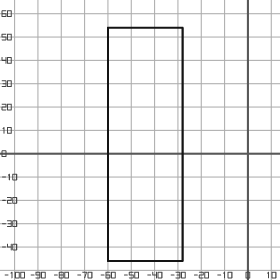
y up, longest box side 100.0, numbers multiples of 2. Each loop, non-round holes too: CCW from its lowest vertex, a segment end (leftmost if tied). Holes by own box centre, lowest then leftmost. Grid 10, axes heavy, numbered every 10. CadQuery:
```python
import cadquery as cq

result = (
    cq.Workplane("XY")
    .moveTo(-60.0, -46.0)
    .lineTo(-28.0, -46.0)
    .lineTo(-28.0, 54.0)
    .lineTo(-60.0, 54.0)
    .close()
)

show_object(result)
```